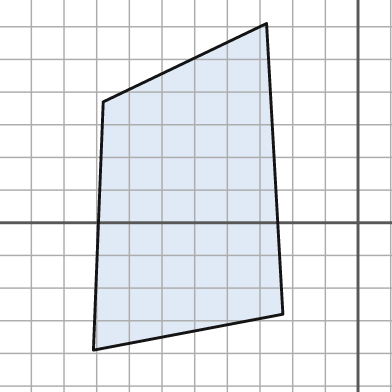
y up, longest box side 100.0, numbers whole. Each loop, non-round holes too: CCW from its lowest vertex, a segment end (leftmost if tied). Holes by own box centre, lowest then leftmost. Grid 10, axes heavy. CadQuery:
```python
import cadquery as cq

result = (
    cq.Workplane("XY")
    .moveTo(-81.0, -39.0)
    .lineTo(-23.0, -28.0)
    .lineTo(-28.0, 61.0)
    .lineTo(-78.0, 37.0)
    .close()
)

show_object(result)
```